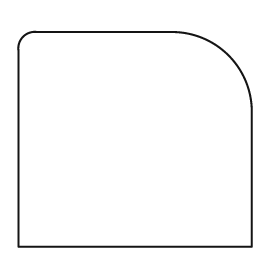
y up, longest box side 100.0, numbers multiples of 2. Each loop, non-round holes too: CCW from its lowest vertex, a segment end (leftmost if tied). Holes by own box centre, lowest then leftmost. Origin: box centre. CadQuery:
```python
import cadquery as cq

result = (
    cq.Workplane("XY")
    .moveTo(-50.0, -46.0)
    .lineTo(50.0, -46.0)
    .lineTo(50.0, 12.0)
    .threePointArc((40.0, 36.0), (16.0, 46.0))
    .lineTo(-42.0, 46.0)
    .threePointArc((-48.0, 44.0), (-50.0, 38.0))
    .close()
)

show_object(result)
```